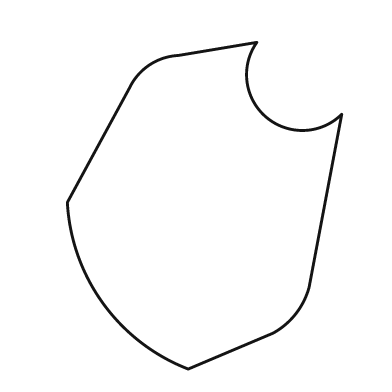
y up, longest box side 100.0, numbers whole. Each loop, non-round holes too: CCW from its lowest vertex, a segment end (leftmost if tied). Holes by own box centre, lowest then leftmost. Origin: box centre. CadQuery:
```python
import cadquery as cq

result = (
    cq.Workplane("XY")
    .moveTo(-5.0, -50.0)
    .lineTo(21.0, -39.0)
    .threePointArc((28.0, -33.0), (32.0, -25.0))
    .lineTo(42.0, 28.0)
    .threePointArc((19.0, 27.0), (16.0, 50.0))
    .lineTo(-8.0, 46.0)
    .threePointArc((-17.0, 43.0), (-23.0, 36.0))
    .lineTo(-42.0, 1.0)
    .threePointArc((-31.0, -30.0), (-5.0, -50.0))
    .close()
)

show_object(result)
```